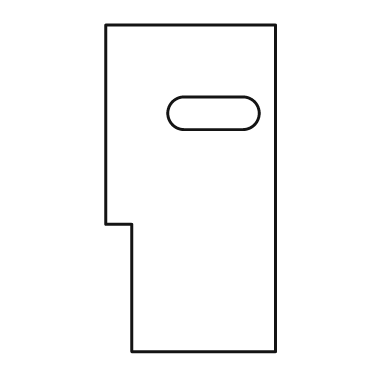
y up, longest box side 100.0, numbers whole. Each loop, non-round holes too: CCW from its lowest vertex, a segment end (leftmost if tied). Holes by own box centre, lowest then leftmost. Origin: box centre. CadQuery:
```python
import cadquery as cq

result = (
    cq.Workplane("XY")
    .moveTo(-18.0, -50.0)
    .lineTo(26.0, -50.0)
    .lineTo(26.0, 50.0)
    .lineTo(-26.0, 50.0)
    .lineTo(-26.0, -11.0)
    .lineTo(-18.0, -11.0)
    .close()
    .moveTo(-2.0, 18.0)
    .lineTo(16.0, 18.0)
    .threePointArc((21.0, 23.0), (16.0, 28.0))
    .lineTo(-2.0, 28.0)
    .threePointArc((-7.0, 23.0), (-2.0, 18.0))
    .close()
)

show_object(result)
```